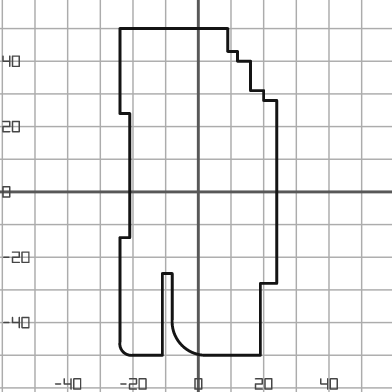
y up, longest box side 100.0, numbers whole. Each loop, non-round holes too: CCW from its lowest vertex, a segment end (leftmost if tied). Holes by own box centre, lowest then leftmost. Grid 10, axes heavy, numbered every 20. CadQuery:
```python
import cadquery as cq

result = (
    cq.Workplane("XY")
    .moveTo(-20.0, -50.0)
    .lineTo(-11.0, -50.0)
    .lineTo(-11.0, -25.0)
    .lineTo(-8.0, -25.0)
    .lineTo(-8.0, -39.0)
    .threePointArc((-5.0, -47.0), (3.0, -50.0))
    .lineTo(19.0, -50.0)
    .lineTo(19.0, -28.0)
    .lineTo(24.0, -28.0)
    .lineTo(24.0, 28.0)
    .lineTo(20.0, 28.0)
    .lineTo(20.0, 31.0)
    .lineTo(16.0, 31.0)
    .lineTo(16.0, 40.0)
    .lineTo(12.0, 40.0)
    .lineTo(12.0, 43.0)
    .lineTo(9.0, 43.0)
    .lineTo(9.0, 50.0)
    .lineTo(-24.0, 50.0)
    .lineTo(-24.0, 24.0)
    .lineTo(-21.0, 24.0)
    .lineTo(-21.0, -14.0)
    .lineTo(-24.0, -14.0)
    .lineTo(-24.0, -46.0)
    .threePointArc((-23.0, -49.0), (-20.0, -50.0))
    .close()
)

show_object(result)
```